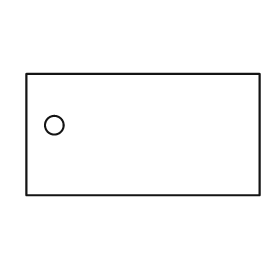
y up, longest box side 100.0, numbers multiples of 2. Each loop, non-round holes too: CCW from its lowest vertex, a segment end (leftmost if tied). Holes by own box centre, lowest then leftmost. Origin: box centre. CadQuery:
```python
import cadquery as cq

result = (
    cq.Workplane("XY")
    .moveTo(-50.0, -26.0)
    .lineTo(50.0, -26.0)
    .lineTo(50.0, 26.0)
    .lineTo(-50.0, 26.0)
    .close()
    .moveTo(-38.0, 4.0)
    .circle(4.0)
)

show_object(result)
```